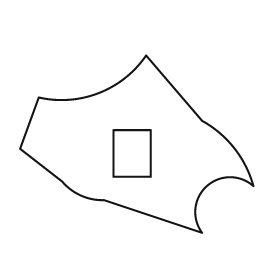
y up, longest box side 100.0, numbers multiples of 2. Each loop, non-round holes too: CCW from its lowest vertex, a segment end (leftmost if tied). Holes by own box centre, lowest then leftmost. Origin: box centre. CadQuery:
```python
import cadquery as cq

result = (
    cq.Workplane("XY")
    .moveTo(28.0, -38.0)
    .threePointArc((30.0, -18.0), (50.0, -18.0))
    .threePointArc((42.0, -2.0), (28.0, 10.0))
    .lineTo(4.0, 38.0)
    .threePointArc((-16.0, 22.0), (-42.0, 20.0))
    .lineTo(-50.0, -2.0)
    .lineTo(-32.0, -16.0)
    .threePointArc((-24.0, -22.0), (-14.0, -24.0))
    .close()
    .moveTo(-10.0, -14.0)
    .lineTo(6.0, -14.0)
    .lineTo(6.0, 6.0)
    .lineTo(-10.0, 6.0)
    .close()
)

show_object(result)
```